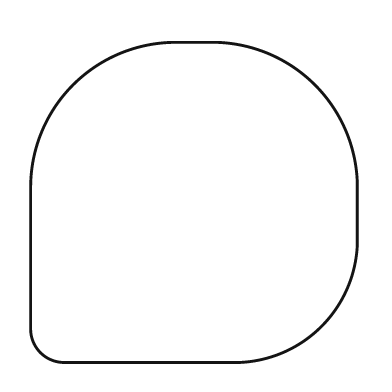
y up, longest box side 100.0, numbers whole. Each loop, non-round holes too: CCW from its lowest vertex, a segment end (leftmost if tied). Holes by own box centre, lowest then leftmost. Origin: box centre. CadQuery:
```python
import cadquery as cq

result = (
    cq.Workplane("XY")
    .moveTo(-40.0, -49.0)
    .lineTo(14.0, -49.0)
    .threePointArc((39.0, -38.0), (50.0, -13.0))
    .lineTo(50.0, 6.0)
    .threePointArc((37.0, 36.0), (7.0, 49.0))
    .lineTo(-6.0, 49.0)
    .threePointArc((-37.0, 36.0), (-50.0, 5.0))
    .lineTo(-50.0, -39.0)
    .threePointArc((-47.0, -46.0), (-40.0, -49.0))
    .close()
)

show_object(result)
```